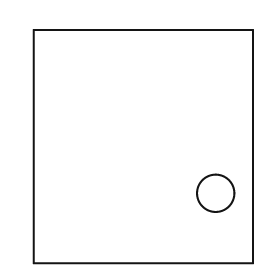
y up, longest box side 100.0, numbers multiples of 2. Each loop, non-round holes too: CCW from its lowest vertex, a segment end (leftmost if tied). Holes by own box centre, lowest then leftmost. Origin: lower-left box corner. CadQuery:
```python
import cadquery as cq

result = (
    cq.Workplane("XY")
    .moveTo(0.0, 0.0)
    .lineTo(94.0, 0.0)
    .lineTo(94.0, 100.0)
    .lineTo(0.0, 100.0)
    .close()
    .moveTo(78.0, 30.0)
    .circle(8.0)
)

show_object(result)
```